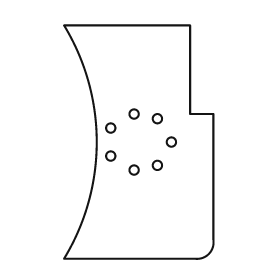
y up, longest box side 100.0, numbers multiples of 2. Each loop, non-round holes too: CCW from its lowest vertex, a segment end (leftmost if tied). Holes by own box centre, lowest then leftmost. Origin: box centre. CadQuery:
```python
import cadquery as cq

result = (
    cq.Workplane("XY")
    .moveTo(-32.0, -50.0)
    .lineTo(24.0, -50.0)
    .threePointArc((30.0, -48.0), (32.0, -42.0))
    .lineTo(32.0, 12.0)
    .lineTo(22.0, 12.0)
    .lineTo(22.0, 50.0)
    .lineTo(-32.0, 50.0)
    .threePointArc((-18.0, 0.0), (-32.0, -50.0))
    .close()
    .moveTo(-2.0, -12.0)
    .circle(2.0)
    .moveTo(8.0, -10.0)
    .circle(2.0)
    .moveTo(-12.0, -6.0)
    .circle(2.0)
    .moveTo(14.0, 0.0)
    .circle(2.0)
    .moveTo(-12.0, 6.0)
    .circle(2.0)
    .moveTo(8.0, 10.0)
    .circle(2.0)
    .moveTo(-2.0, 12.0)
    .circle(2.0)
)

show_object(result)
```